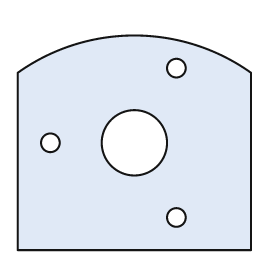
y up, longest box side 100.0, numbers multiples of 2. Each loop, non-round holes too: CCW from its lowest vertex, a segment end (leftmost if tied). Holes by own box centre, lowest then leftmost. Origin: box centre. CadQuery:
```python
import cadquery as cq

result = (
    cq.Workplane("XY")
    .moveTo(-50.0, -46.0)
    .lineTo(50.0, -46.0)
    .lineTo(50.0, 30.0)
    .threePointArc((0.0, 46.0), (-50.0, 30.0))
    .close()
    .moveTo(18.0, -32.0)
    .circle(4.0)
    .moveTo(-36.0, 0.0)
    .circle(4.0)
    .moveTo(0.0, 0.0)
    .circle(14.0)
    .moveTo(18.0, 32.0)
    .circle(4.0)
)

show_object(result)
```